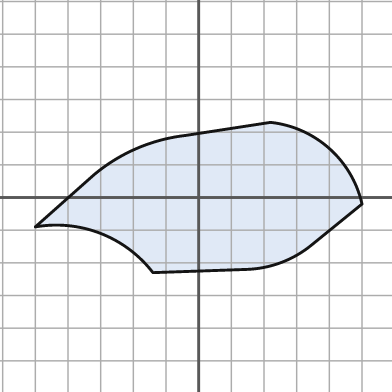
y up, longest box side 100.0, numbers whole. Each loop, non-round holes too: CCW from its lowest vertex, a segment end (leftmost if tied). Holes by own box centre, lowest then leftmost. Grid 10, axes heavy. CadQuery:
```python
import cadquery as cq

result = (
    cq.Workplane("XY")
    .moveTo(-14.0, -23.0)
    .lineTo(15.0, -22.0)
    .threePointArc((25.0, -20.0), (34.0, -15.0))
    .lineTo(50.0, -2.0)
    .threePointArc((40.0, 15.0), (22.0, 23.0))
    .lineTo(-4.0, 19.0)
    .threePointArc((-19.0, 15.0), (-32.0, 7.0))
    .lineTo(-50.0, -9.0)
    .threePointArc((-30.0, -11.0), (-14.0, -23.0))
    .close()
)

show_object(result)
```